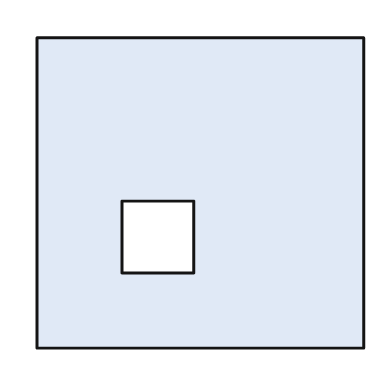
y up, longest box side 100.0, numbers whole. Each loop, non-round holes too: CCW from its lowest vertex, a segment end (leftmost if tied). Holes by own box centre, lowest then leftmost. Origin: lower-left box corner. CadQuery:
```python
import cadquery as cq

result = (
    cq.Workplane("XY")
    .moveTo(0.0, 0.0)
    .lineTo(100.0, 0.0)
    .lineTo(100.0, 95.0)
    .lineTo(0.0, 95.0)
    .close()
    .moveTo(26.0, 23.0)
    .lineTo(48.0, 23.0)
    .lineTo(48.0, 45.0)
    .lineTo(26.0, 45.0)
    .close()
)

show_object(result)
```